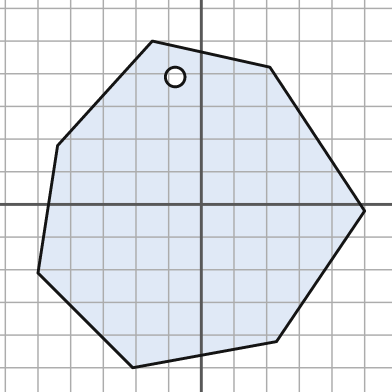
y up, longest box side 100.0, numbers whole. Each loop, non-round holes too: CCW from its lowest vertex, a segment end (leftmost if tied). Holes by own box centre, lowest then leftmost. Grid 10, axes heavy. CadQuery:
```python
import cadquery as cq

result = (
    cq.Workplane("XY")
    .moveTo(-21.0, -50.0)
    .lineTo(23.0, -42.0)
    .lineTo(50.0, -2.0)
    .lineTo(21.0, 42.0)
    .lineTo(-15.0, 50.0)
    .lineTo(-44.0, 18.0)
    .lineTo(-50.0, -21.0)
    .close()
    .moveTo(-8.0, 39.0)
    .circle(3.0)
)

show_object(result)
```